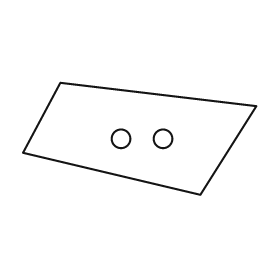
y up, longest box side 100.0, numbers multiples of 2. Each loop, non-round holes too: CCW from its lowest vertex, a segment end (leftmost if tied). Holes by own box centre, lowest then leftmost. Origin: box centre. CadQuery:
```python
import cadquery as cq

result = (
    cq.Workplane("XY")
    .moveTo(26.0, -24.0)
    .lineTo(50.0, 14.0)
    .lineTo(-34.0, 24.0)
    .lineTo(-50.0, -6.0)
    .close()
    .moveTo(-8.0, 0.0)
    .circle(4.0)
    .moveTo(10.0, 0.0)
    .circle(4.0)
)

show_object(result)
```